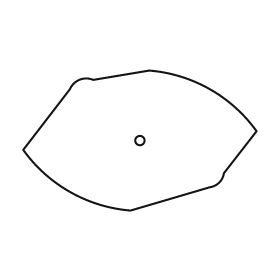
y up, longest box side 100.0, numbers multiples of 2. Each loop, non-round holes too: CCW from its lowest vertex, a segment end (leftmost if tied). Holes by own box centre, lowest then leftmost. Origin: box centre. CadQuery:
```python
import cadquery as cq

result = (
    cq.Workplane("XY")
    .moveTo(-4.0, -30.0)
    .lineTo(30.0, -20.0)
    .threePointArc((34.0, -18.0), (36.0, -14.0))
    .lineTo(50.0, 4.0)
    .threePointArc((30.0, 22.0), (4.0, 30.0))
    .lineTo(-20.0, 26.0)
    .threePointArc((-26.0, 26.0), (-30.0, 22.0))
    .lineTo(-50.0, -4.0)
    .threePointArc((-30.0, -22.0), (-4.0, -30.0))
    .close()
    .moveTo(0.0, 0.0)
    .circle(2.0)
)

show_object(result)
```